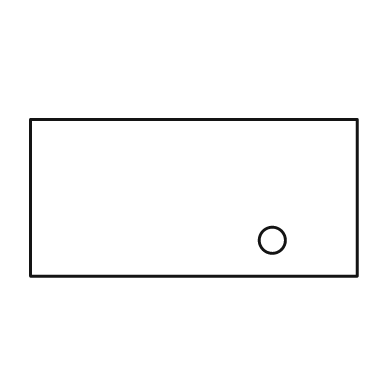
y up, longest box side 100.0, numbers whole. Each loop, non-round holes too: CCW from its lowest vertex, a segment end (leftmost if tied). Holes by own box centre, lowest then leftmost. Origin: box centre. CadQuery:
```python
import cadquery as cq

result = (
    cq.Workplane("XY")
    .moveTo(-50.0, -24.0)
    .lineTo(50.0, -24.0)
    .lineTo(50.0, 24.0)
    .lineTo(-50.0, 24.0)
    .close()
    .moveTo(24.0, -13.0)
    .circle(4.0)
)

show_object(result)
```